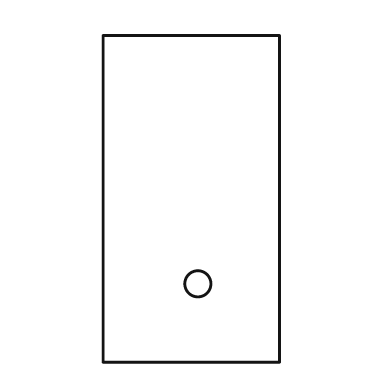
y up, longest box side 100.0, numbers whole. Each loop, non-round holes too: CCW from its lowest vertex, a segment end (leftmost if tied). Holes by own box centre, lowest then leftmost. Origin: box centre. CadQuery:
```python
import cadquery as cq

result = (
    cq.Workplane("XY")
    .moveTo(-27.0, -50.0)
    .lineTo(27.0, -50.0)
    .lineTo(27.0, 50.0)
    .lineTo(-27.0, 50.0)
    .close()
    .moveTo(2.0, -26.0)
    .circle(4.0)
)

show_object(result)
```